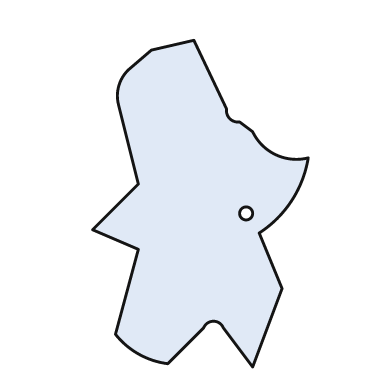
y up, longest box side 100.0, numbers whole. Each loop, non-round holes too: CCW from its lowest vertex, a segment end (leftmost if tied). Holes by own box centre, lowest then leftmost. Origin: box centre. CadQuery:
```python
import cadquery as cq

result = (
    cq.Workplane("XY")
    .moveTo(16.0, -50.0)
    .lineTo(25.0, -26.0)
    .lineTo(18.0, -9.0)
    .threePointArc((28.0, 1.0), (33.0, 14.0))
    .threePointArc((23.0, 15.0), (16.0, 22.0))
    .lineTo(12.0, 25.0)
    .threePointArc((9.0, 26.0), (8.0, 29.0))
    .lineTo(-2.0, 50.0)
    .lineTo(-15.0, 47.0)
    .lineTo(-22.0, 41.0)
    .threePointArc((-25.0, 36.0), (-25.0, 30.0))
    .lineTo(-19.0, 6.0)
    .lineTo(-33.0, -8.0)
    .lineTo(-19.0, -14.0)
    .lineTo(-26.0, -40.0)
    .threePointArc((-19.0, -46.0), (-10.0, -49.0))
    .lineTo(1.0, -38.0)
    .threePointArc((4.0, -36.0), (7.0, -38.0))
    .close()
    .moveTo(14.0, -3.0)
    .circle(2.0)
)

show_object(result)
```